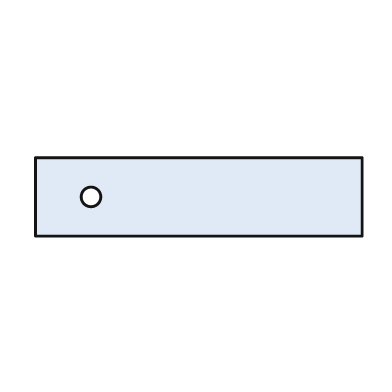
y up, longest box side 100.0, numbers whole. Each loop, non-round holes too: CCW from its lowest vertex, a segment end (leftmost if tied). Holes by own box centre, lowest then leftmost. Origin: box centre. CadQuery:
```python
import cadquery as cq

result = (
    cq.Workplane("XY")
    .moveTo(-50.0, -12.0)
    .lineTo(50.0, -12.0)
    .lineTo(50.0, 12.0)
    .lineTo(-50.0, 12.0)
    .close()
    .moveTo(-33.0, 0.0)
    .circle(3.0)
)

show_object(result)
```